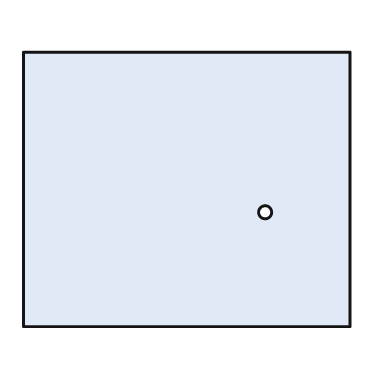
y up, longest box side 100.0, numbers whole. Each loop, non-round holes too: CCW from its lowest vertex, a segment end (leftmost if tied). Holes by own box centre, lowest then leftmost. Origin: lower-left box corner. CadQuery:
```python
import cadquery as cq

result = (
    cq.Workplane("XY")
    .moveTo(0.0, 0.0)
    .lineTo(100.0, 0.0)
    .lineTo(100.0, 84.0)
    .lineTo(0.0, 84.0)
    .close()
    .moveTo(74.0, 35.0)
    .circle(2.0)
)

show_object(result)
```